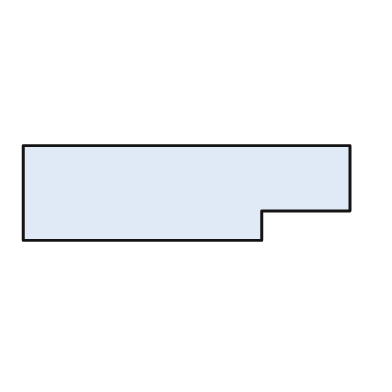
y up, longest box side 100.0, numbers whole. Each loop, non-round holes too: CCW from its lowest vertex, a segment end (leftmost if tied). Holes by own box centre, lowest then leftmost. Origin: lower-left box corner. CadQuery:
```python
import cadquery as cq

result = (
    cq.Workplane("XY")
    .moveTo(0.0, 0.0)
    .lineTo(73.0, 0.0)
    .lineTo(73.0, 9.0)
    .lineTo(100.0, 9.0)
    .lineTo(100.0, 29.0)
    .lineTo(0.0, 29.0)
    .close()
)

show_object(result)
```